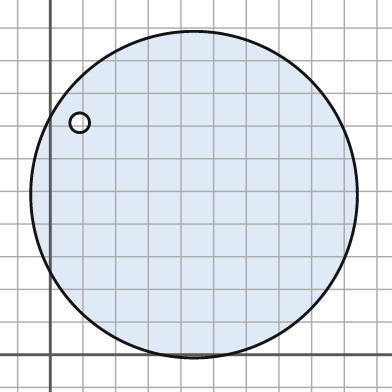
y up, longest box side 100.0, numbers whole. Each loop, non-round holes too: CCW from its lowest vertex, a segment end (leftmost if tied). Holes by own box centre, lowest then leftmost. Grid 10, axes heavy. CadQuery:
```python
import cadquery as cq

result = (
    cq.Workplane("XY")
    .moveTo(44.0, 49.0)
    .circle(50.0)
    .moveTo(9.0, 71.0)
    .circle(3.0)
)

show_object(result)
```